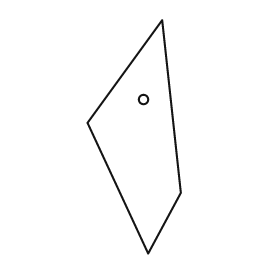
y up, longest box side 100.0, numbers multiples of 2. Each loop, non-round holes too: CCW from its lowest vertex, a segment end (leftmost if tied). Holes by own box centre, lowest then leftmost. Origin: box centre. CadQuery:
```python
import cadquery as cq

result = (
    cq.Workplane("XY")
    .moveTo(6.0, -50.0)
    .lineTo(20.0, -24.0)
    .lineTo(12.0, 50.0)
    .lineTo(-20.0, 6.0)
    .close()
    .moveTo(4.0, 16.0)
    .circle(2.0)
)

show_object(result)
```